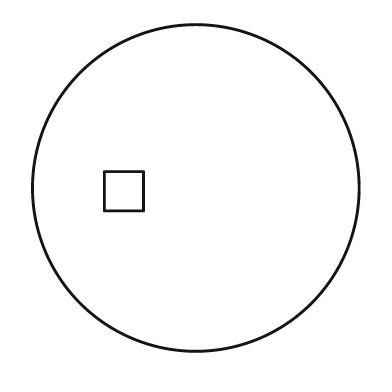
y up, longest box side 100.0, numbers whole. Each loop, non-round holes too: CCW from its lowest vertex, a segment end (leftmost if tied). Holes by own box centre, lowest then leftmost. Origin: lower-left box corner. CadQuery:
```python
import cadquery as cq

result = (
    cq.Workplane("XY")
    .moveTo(50.0, 50.0)
    .circle(50.0)
    .moveTo(22.0, 43.0)
    .lineTo(34.0, 43.0)
    .lineTo(34.0, 55.0)
    .lineTo(22.0, 55.0)
    .close()
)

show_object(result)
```